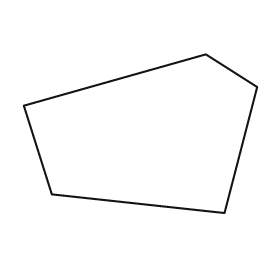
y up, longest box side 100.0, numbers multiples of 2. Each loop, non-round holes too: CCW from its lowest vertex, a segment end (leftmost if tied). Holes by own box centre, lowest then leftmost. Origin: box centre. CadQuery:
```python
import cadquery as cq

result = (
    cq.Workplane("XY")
    .moveTo(36.0, -34.0)
    .lineTo(50.0, 20.0)
    .lineTo(28.0, 34.0)
    .lineTo(-50.0, 12.0)
    .lineTo(-38.0, -26.0)
    .close()
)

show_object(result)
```